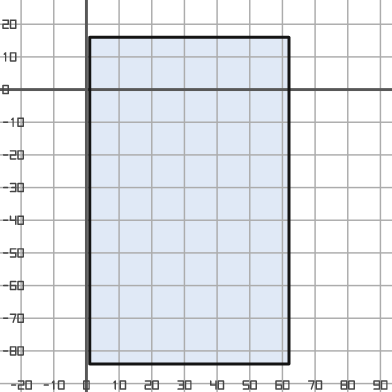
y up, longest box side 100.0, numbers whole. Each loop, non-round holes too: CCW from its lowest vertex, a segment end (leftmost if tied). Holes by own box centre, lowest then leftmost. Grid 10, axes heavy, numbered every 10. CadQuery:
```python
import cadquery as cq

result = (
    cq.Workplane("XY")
    .moveTo(1.0, -84.0)
    .lineTo(62.0, -84.0)
    .lineTo(62.0, 16.0)
    .lineTo(1.0, 16.0)
    .close()
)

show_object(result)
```